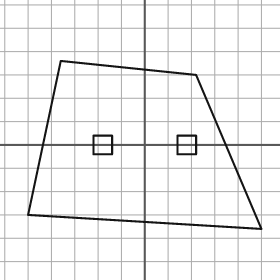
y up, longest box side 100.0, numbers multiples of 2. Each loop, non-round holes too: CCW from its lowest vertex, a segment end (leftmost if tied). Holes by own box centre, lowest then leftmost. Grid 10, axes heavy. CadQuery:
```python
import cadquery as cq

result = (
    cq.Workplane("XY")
    .moveTo(50.0, -36.0)
    .lineTo(22.0, 30.0)
    .lineTo(-36.0, 36.0)
    .lineTo(-50.0, -30.0)
    .close()
    .moveTo(-22.0, -4.0)
    .lineTo(-14.0, -4.0)
    .lineTo(-14.0, 4.0)
    .lineTo(-22.0, 4.0)
    .close()
    .moveTo(14.0, -4.0)
    .lineTo(22.0, -4.0)
    .lineTo(22.0, 4.0)
    .lineTo(14.0, 4.0)
    .close()
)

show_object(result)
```